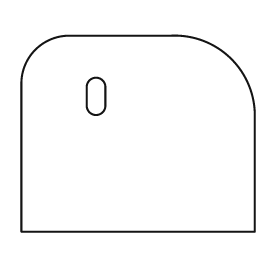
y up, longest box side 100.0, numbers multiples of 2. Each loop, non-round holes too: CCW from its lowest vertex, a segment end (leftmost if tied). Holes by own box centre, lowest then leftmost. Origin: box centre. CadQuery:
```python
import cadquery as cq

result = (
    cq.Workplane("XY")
    .moveTo(-50.0, -42.0)
    .lineTo(50.0, -42.0)
    .lineTo(50.0, 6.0)
    .threePointArc((40.0, 32.0), (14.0, 42.0))
    .lineTo(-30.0, 42.0)
    .threePointArc((-44.0, 36.0), (-50.0, 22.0))
    .close()
    .moveTo(-22.0, 12.0)
    .threePointArc((-18.0, 8.0), (-14.0, 12.0))
    .lineTo(-14.0, 20.0)
    .threePointArc((-18.0, 24.0), (-22.0, 20.0))
    .close()
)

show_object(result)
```